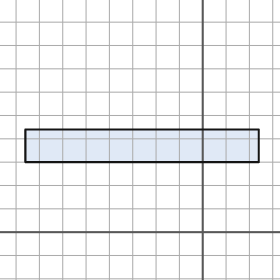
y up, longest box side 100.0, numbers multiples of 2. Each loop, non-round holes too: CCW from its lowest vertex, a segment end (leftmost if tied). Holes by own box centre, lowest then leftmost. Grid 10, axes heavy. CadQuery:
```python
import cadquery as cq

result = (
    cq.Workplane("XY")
    .moveTo(-76.0, 30.0)
    .lineTo(24.0, 30.0)
    .lineTo(24.0, 44.0)
    .lineTo(-76.0, 44.0)
    .close()
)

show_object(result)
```